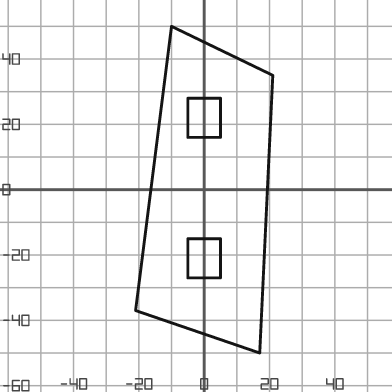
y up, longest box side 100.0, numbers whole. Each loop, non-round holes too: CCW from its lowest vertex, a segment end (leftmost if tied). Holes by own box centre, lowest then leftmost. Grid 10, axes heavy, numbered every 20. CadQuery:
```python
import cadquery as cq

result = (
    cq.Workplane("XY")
    .moveTo(17.0, -50.0)
    .lineTo(21.0, 35.0)
    .lineTo(-10.0, 50.0)
    .lineTo(-21.0, -37.0)
    .close()
    .moveTo(-5.0, -27.0)
    .lineTo(5.0, -27.0)
    .lineTo(5.0, -15.0)
    .lineTo(-5.0, -15.0)
    .close()
    .moveTo(-5.0, 16.0)
    .lineTo(5.0, 16.0)
    .lineTo(5.0, 28.0)
    .lineTo(-5.0, 28.0)
    .close()
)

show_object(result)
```